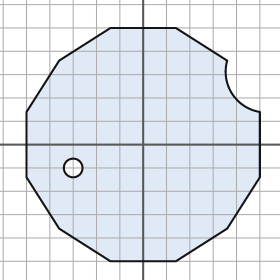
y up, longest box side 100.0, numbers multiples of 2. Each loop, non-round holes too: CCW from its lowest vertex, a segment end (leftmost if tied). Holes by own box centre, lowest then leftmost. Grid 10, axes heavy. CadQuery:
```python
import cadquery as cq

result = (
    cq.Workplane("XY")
    .moveTo(-14.0, -50.0)
    .lineTo(14.0, -50.0)
    .lineTo(36.0, -36.0)
    .lineTo(50.0, -14.0)
    .lineTo(50.0, 14.0)
    .threePointArc((38.0, 22.0), (36.0, 36.0))
    .lineTo(14.0, 50.0)
    .lineTo(-14.0, 50.0)
    .lineTo(-36.0, 36.0)
    .lineTo(-50.0, 14.0)
    .lineTo(-50.0, -14.0)
    .lineTo(-36.0, -36.0)
    .close()
    .moveTo(-30.0, -10.0)
    .circle(4.0)
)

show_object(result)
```